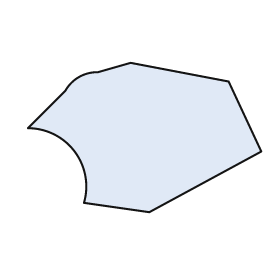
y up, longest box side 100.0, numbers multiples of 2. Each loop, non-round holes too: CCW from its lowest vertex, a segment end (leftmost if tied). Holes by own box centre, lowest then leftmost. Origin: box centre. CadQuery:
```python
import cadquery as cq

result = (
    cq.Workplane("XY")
    .moveTo(2.0, -32.0)
    .lineTo(50.0, -6.0)
    .lineTo(36.0, 24.0)
    .lineTo(-6.0, 32.0)
    .lineTo(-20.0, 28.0)
    .threePointArc((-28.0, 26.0), (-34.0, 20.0))
    .lineTo(-50.0, 4.0)
    .threePointArc((-30.0, -6.0), (-26.0, -28.0))
    .close()
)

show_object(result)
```